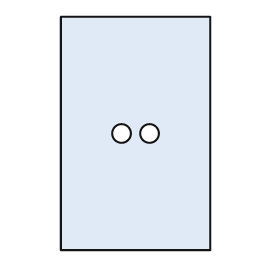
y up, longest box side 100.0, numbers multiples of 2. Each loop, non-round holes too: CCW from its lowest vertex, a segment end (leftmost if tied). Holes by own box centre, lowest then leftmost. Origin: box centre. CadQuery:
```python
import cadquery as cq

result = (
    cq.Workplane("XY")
    .moveTo(-32.0, -50.0)
    .lineTo(32.0, -50.0)
    .lineTo(32.0, 50.0)
    .lineTo(-32.0, 50.0)
    .close()
    .moveTo(-6.0, 0.0)
    .circle(4.0)
    .moveTo(6.0, 0.0)
    .circle(4.0)
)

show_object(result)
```